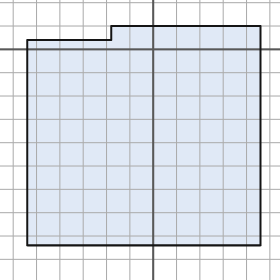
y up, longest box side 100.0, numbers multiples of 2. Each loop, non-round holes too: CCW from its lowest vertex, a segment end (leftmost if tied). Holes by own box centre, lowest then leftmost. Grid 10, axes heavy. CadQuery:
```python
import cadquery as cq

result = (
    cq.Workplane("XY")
    .moveTo(-54.0, -84.0)
    .lineTo(46.0, -84.0)
    .lineTo(46.0, 10.0)
    .lineTo(-18.0, 10.0)
    .lineTo(-18.0, 4.0)
    .lineTo(-54.0, 4.0)
    .close()
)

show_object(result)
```